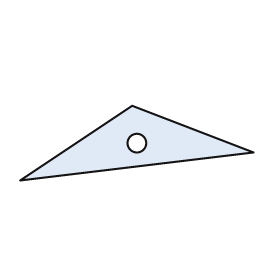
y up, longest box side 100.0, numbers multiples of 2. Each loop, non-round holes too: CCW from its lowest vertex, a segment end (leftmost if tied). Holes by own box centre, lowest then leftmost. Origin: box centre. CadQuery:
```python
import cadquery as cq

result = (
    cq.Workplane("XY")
    .moveTo(-50.0, -16.0)
    .lineTo(50.0, -4.0)
    .lineTo(-2.0, 16.0)
    .close()
    .moveTo(0.0, 0.0)
    .circle(4.0)
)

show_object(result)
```